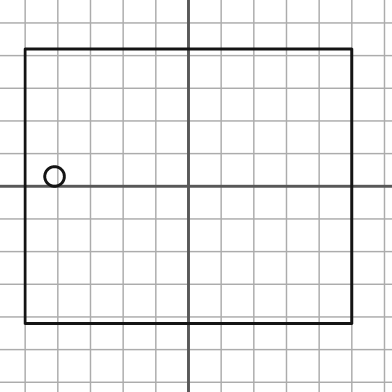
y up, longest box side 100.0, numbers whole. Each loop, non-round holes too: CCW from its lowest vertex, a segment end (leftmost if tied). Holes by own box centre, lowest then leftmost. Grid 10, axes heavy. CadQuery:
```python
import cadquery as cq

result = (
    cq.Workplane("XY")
    .moveTo(-50.0, -42.0)
    .lineTo(50.0, -42.0)
    .lineTo(50.0, 42.0)
    .lineTo(-50.0, 42.0)
    .close()
    .moveTo(-41.0, 3.0)
    .circle(3.0)
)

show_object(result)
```